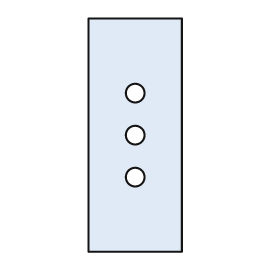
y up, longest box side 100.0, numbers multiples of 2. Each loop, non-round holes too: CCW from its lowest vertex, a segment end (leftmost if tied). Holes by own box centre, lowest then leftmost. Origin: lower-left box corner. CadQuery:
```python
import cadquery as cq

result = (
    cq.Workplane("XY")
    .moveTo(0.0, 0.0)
    .lineTo(40.0, 0.0)
    .lineTo(40.0, 100.0)
    .lineTo(0.0, 100.0)
    .close()
    .moveTo(20.0, 32.0)
    .circle(4.0)
    .moveTo(20.0, 50.0)
    .circle(4.0)
    .moveTo(20.0, 68.0)
    .circle(4.0)
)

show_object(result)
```